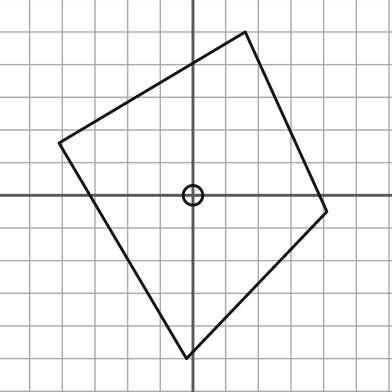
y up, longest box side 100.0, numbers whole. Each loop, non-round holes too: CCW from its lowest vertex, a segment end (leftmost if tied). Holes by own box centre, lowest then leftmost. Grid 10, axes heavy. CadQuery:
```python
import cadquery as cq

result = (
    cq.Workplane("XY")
    .moveTo(-2.0, -50.0)
    .lineTo(41.0, -5.0)
    .lineTo(16.0, 50.0)
    .lineTo(-41.0, 16.0)
    .close()
    .moveTo(0.0, 0.0)
    .circle(3.0)
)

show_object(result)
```